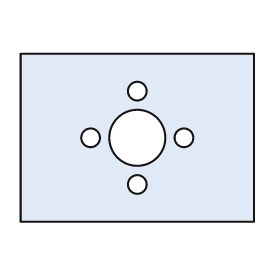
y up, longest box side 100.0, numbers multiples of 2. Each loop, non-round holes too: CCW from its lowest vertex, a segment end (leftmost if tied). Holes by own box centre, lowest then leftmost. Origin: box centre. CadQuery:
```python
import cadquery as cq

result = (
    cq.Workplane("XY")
    .moveTo(-50.0, -36.0)
    .lineTo(50.0, -36.0)
    .lineTo(50.0, 36.0)
    .lineTo(-50.0, 36.0)
    .close()
    .moveTo(0.0, -20.0)
    .circle(4.0)
    .moveTo(-20.0, 0.0)
    .circle(4.0)
    .moveTo(0.0, 0.0)
    .circle(12.0)
    .moveTo(20.0, 0.0)
    .circle(4.0)
    .moveTo(0.0, 20.0)
    .circle(4.0)
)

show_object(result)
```